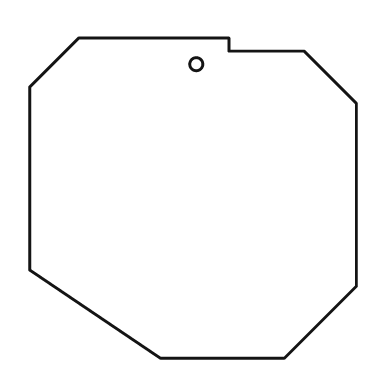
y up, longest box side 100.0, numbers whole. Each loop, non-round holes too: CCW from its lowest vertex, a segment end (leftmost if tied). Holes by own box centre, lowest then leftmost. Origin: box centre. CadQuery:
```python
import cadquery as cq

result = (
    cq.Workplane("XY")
    .moveTo(-10.0, -49.0)
    .lineTo(28.0, -49.0)
    .lineTo(50.0, -27.0)
    .lineTo(50.0, 29.0)
    .lineTo(34.0, 45.0)
    .lineTo(11.0, 45.0)
    .lineTo(11.0, 49.0)
    .lineTo(-35.0, 49.0)
    .lineTo(-50.0, 34.0)
    .lineTo(-50.0, -22.0)
    .close()
    .moveTo(1.0, 41.0)
    .circle(2.0)
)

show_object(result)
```